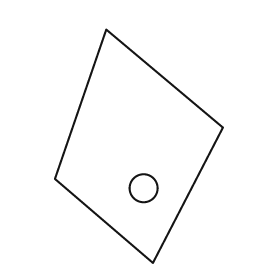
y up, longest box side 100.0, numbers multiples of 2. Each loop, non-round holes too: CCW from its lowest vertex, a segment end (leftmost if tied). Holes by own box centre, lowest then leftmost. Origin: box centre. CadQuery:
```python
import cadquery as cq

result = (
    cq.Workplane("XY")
    .moveTo(6.0, -50.0)
    .lineTo(36.0, 8.0)
    .lineTo(-14.0, 50.0)
    .lineTo(-36.0, -14.0)
    .close()
    .moveTo(2.0, -18.0)
    .circle(6.0)
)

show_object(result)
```